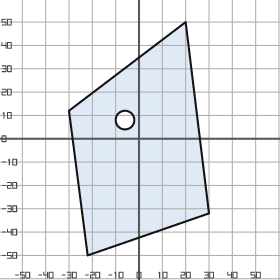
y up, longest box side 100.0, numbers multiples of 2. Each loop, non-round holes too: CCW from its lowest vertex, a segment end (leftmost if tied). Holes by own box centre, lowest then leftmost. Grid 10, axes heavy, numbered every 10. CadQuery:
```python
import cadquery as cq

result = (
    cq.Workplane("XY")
    .moveTo(-22.0, -50.0)
    .lineTo(30.0, -32.0)
    .lineTo(20.0, 50.0)
    .lineTo(-30.0, 12.0)
    .close()
    .moveTo(-6.0, 8.0)
    .circle(4.0)
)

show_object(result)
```